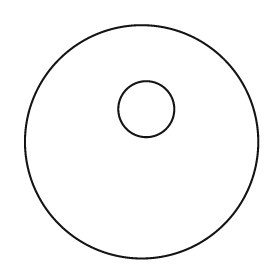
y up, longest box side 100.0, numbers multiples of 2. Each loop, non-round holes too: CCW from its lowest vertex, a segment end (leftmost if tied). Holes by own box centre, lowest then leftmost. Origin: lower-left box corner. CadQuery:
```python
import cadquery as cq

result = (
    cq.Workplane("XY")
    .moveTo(50.0, 50.0)
    .circle(50.0)
    .moveTo(52.0, 64.0)
    .circle(12.0)
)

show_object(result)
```